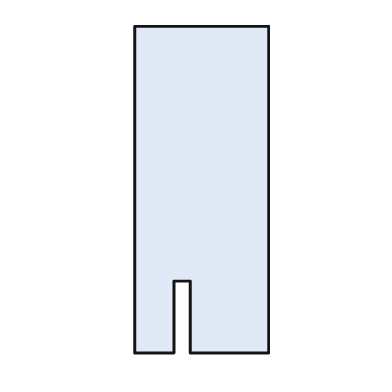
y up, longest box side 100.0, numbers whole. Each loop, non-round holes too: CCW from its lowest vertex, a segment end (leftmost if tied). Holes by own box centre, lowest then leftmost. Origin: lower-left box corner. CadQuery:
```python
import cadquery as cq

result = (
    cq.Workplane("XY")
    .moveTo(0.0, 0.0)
    .lineTo(12.0, 0.0)
    .lineTo(12.0, 22.0)
    .lineTo(17.0, 22.0)
    .lineTo(17.0, 0.0)
    .lineTo(41.0, 0.0)
    .lineTo(41.0, 100.0)
    .lineTo(0.0, 100.0)
    .close()
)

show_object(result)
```